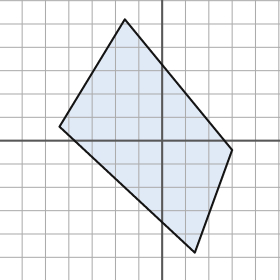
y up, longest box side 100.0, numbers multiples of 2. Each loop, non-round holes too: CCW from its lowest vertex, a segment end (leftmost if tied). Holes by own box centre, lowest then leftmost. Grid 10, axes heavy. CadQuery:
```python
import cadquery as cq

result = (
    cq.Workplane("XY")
    .moveTo(14.0, -48.0)
    .lineTo(30.0, -4.0)
    .lineTo(-16.0, 52.0)
    .lineTo(-44.0, 6.0)
    .close()
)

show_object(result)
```